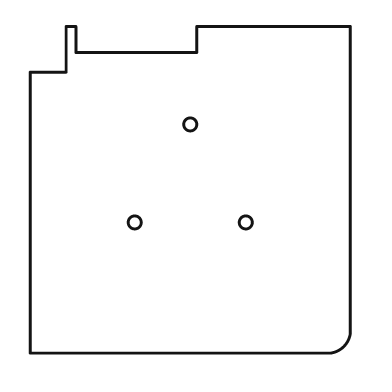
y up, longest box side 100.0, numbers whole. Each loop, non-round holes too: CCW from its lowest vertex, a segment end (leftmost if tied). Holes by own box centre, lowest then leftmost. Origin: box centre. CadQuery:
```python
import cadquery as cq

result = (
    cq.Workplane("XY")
    .moveTo(-49.0, -50.0)
    .lineTo(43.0, -50.0)
    .threePointArc((47.0, -48.0), (49.0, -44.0))
    .lineTo(49.0, 50.0)
    .lineTo(2.0, 50.0)
    .lineTo(2.0, 42.0)
    .lineTo(-35.0, 42.0)
    .lineTo(-35.0, 50.0)
    .lineTo(-38.0, 50.0)
    .lineTo(-38.0, 36.0)
    .lineTo(-49.0, 36.0)
    .close()
    .moveTo(-17.0, -10.0)
    .circle(2.0)
    .moveTo(17.0, -10.0)
    .circle(2.0)
    .moveTo(0.0, 20.0)
    .circle(2.0)
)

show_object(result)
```